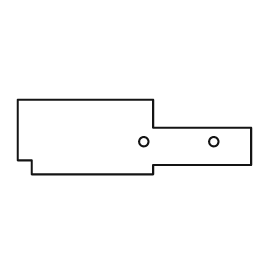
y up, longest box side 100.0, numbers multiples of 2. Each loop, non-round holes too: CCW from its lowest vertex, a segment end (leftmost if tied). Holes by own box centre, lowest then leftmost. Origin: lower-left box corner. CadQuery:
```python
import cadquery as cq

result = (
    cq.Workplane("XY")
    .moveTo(6.0, 0.0)
    .lineTo(58.0, 0.0)
    .lineTo(58.0, 4.0)
    .lineTo(100.0, 4.0)
    .lineTo(100.0, 20.0)
    .lineTo(58.0, 20.0)
    .lineTo(58.0, 32.0)
    .lineTo(0.0, 32.0)
    .lineTo(0.0, 6.0)
    .lineTo(6.0, 6.0)
    .close()
    .moveTo(54.0, 14.0)
    .circle(2.0)
    .moveTo(84.0, 14.0)
    .circle(2.0)
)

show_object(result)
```